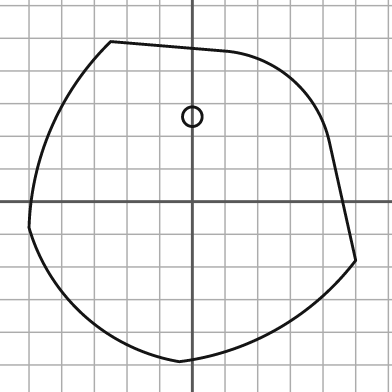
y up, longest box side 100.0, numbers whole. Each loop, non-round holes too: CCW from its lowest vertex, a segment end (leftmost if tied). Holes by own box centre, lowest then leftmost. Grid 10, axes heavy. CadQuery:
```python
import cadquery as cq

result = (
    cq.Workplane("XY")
    .moveTo(-4.0, -49.0)
    .threePointArc((26.0, -39.0), (50.0, -18.0))
    .lineTo(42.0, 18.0)
    .threePointArc((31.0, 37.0), (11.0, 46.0))
    .lineTo(-25.0, 49.0)
    .threePointArc((-43.0, 23.0), (-50.0, -8.0))
    .threePointArc((-33.0, -35.0), (-4.0, -49.0))
    .close()
    .moveTo(0.0, 26.0)
    .circle(3.0)
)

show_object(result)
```